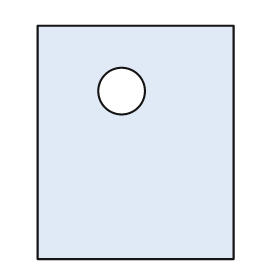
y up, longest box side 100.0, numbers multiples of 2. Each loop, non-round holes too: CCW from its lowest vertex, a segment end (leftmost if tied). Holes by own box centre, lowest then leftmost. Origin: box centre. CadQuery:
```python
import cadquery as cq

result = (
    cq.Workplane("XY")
    .moveTo(-42.0, -50.0)
    .lineTo(42.0, -50.0)
    .lineTo(42.0, 50.0)
    .lineTo(-42.0, 50.0)
    .close()
    .moveTo(-6.0, 22.0)
    .circle(10.0)
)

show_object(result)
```